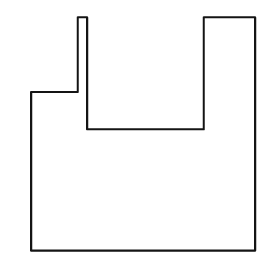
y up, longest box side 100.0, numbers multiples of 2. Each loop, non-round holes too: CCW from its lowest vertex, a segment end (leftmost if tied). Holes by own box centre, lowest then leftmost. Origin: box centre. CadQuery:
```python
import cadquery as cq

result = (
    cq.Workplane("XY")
    .moveTo(-48.0, -50.0)
    .lineTo(48.0, -50.0)
    .lineTo(48.0, 50.0)
    .lineTo(26.0, 50.0)
    .lineTo(26.0, 2.0)
    .lineTo(-24.0, 2.0)
    .lineTo(-24.0, 50.0)
    .lineTo(-28.0, 50.0)
    .lineTo(-28.0, 18.0)
    .lineTo(-48.0, 18.0)
    .close()
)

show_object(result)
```